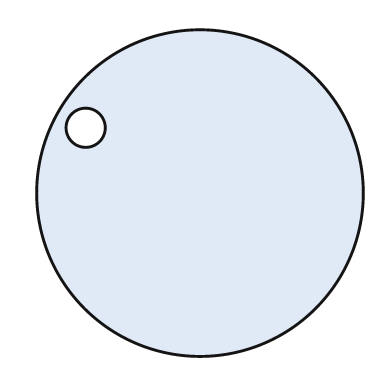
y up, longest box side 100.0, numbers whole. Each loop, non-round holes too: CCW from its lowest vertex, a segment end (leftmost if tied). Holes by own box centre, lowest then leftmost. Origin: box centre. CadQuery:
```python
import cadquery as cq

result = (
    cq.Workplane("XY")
    .moveTo(0.0, 0.0)
    .circle(50.0)
    .moveTo(-35.0, 20.0)
    .circle(6.0)
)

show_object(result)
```